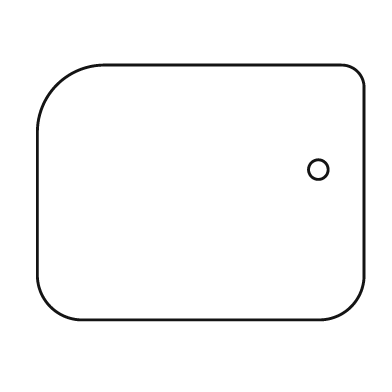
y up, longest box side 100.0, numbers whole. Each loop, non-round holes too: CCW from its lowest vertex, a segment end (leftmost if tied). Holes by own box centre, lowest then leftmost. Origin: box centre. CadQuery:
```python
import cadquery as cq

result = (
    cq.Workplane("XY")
    .moveTo(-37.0, -39.0)
    .lineTo(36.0, -39.0)
    .threePointArc((46.0, -35.0), (50.0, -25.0))
    .lineTo(50.0, 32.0)
    .threePointArc((48.0, 37.0), (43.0, 39.0))
    .lineTo(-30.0, 39.0)
    .threePointArc((-44.0, 33.0), (-50.0, 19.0))
    .lineTo(-50.0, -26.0)
    .threePointArc((-46.0, -35.0), (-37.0, -39.0))
    .close()
    .moveTo(36.0, 7.0)
    .circle(3.0)
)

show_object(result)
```